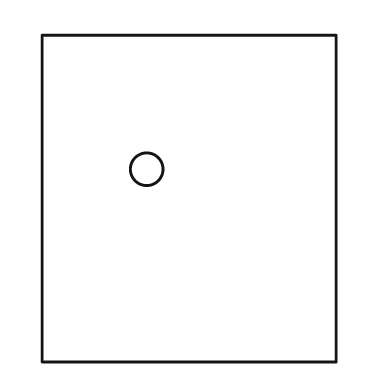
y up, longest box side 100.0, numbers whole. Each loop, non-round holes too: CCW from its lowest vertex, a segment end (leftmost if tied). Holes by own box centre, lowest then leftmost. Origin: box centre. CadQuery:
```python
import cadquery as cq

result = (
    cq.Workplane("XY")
    .moveTo(-45.0, -50.0)
    .lineTo(45.0, -50.0)
    .lineTo(45.0, 50.0)
    .lineTo(-45.0, 50.0)
    .close()
    .moveTo(-13.0, 9.0)
    .circle(5.0)
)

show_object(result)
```